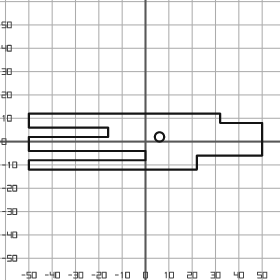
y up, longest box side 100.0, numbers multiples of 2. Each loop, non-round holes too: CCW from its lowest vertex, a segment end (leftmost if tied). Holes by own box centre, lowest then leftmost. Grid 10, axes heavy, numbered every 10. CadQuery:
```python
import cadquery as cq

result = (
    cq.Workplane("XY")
    .moveTo(-50.0, -12.0)
    .lineTo(22.0, -12.0)
    .lineTo(22.0, -6.0)
    .lineTo(50.0, -6.0)
    .lineTo(50.0, 8.0)
    .lineTo(32.0, 8.0)
    .lineTo(32.0, 12.0)
    .lineTo(-50.0, 12.0)
    .lineTo(-50.0, 6.0)
    .lineTo(-16.0, 6.0)
    .lineTo(-16.0, 2.0)
    .lineTo(-50.0, 2.0)
    .lineTo(-50.0, -4.0)
    .lineTo(0.0, -4.0)
    .lineTo(0.0, -8.0)
    .lineTo(-50.0, -8.0)
    .close()
    .moveTo(6.0, 2.0)
    .circle(2.0)
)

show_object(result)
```